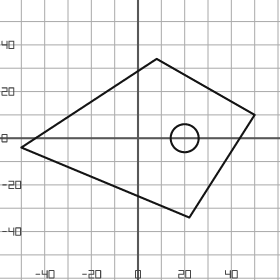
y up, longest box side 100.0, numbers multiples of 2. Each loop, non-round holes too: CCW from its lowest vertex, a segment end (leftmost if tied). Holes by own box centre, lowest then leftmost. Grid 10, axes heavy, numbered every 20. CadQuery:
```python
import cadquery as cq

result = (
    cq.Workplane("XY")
    .moveTo(22.0, -34.0)
    .lineTo(50.0, 10.0)
    .lineTo(8.0, 34.0)
    .lineTo(-50.0, -4.0)
    .close()
    .moveTo(20.0, 0.0)
    .circle(6.0)
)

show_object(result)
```